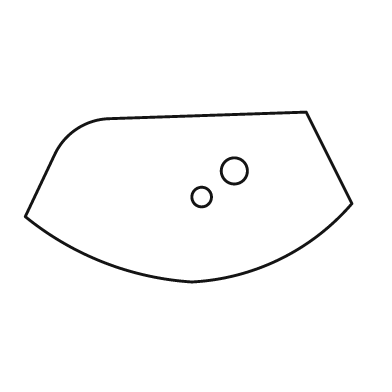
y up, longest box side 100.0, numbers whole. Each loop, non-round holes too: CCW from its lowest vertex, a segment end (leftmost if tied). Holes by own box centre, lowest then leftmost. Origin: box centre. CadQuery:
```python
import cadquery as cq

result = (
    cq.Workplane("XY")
    .moveTo(1.0, -26.0)
    .threePointArc((28.0, -19.0), (50.0, -2.0))
    .lineTo(36.0, 26.0)
    .lineTo(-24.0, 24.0)
    .threePointArc((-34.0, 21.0), (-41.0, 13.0))
    .lineTo(-50.0, -6.0)
    .threePointArc((-26.0, -20.0), (1.0, -26.0))
    .close()
    .moveTo(4.0, 0.0)
    .circle(3.0)
    .moveTo(14.0, 8.0)
    .circle(4.0)
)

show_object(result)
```